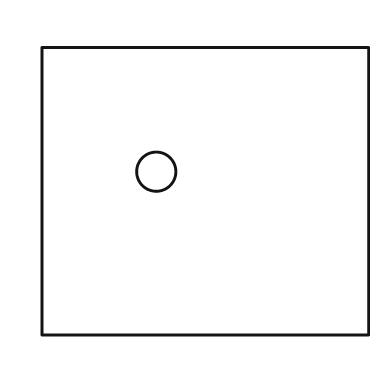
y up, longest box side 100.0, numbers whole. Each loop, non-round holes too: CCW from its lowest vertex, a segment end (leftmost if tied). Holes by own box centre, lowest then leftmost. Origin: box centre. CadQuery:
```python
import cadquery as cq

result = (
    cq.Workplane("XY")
    .moveTo(-50.0, -44.0)
    .lineTo(50.0, -44.0)
    .lineTo(50.0, 44.0)
    .lineTo(-50.0, 44.0)
    .close()
    .moveTo(-15.0, 6.0)
    .circle(6.0)
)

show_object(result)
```